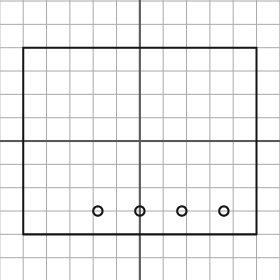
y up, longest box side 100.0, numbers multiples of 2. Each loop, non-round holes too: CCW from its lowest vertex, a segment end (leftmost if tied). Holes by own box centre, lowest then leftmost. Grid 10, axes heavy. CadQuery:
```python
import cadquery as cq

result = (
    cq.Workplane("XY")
    .moveTo(-50.0, -40.0)
    .lineTo(50.0, -40.0)
    .lineTo(50.0, 40.0)
    .lineTo(-50.0, 40.0)
    .close()
    .moveTo(-18.0, -30.0)
    .circle(2.0)
    .moveTo(0.0, -30.0)
    .circle(2.0)
    .moveTo(18.0, -30.0)
    .circle(2.0)
    .moveTo(36.0, -30.0)
    .circle(2.0)
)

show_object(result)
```